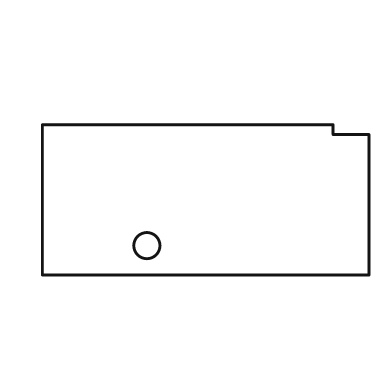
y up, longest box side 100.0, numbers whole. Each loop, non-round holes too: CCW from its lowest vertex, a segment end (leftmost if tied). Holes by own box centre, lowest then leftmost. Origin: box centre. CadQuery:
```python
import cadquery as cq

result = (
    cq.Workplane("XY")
    .moveTo(-50.0, -23.0)
    .lineTo(50.0, -23.0)
    .lineTo(50.0, 20.0)
    .lineTo(39.0, 20.0)
    .lineTo(39.0, 23.0)
    .lineTo(-50.0, 23.0)
    .close()
    .moveTo(-18.0, -14.0)
    .circle(4.0)
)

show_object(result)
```